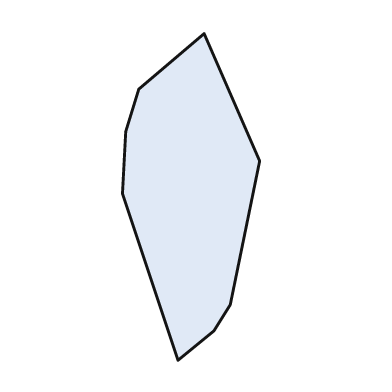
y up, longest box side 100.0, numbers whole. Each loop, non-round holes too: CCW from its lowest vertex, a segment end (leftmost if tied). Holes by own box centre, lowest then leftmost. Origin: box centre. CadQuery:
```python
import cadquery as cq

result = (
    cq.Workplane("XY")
    .moveTo(-4.0, -50.0)
    .lineTo(7.0, -41.0)
    .lineTo(12.0, -33.0)
    .lineTo(21.0, 11.0)
    .lineTo(4.0, 50.0)
    .lineTo(-16.0, 33.0)
    .lineTo(-20.0, 20.0)
    .lineTo(-21.0, 1.0)
    .close()
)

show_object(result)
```